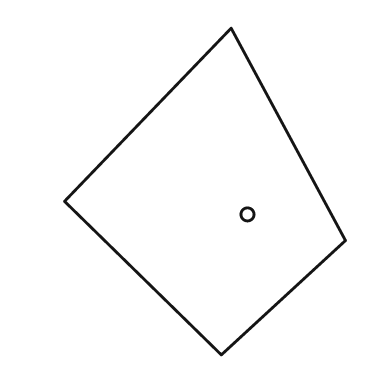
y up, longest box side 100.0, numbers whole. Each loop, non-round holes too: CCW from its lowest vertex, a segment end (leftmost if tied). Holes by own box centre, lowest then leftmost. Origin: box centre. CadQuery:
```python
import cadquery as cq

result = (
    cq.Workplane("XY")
    .moveTo(5.0, -50.0)
    .lineTo(43.0, -15.0)
    .lineTo(8.0, 50.0)
    .lineTo(-43.0, -3.0)
    .close()
    .moveTo(13.0, -7.0)
    .circle(2.0)
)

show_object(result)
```